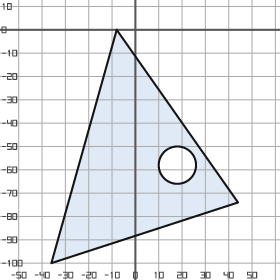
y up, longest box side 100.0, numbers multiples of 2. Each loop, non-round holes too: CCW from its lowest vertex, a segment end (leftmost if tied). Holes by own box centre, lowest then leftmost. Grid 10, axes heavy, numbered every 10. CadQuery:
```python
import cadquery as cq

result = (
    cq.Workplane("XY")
    .moveTo(-36.0, -100.0)
    .lineTo(44.0, -74.0)
    .lineTo(-8.0, 0.0)
    .close()
    .moveTo(18.0, -58.0)
    .circle(8.0)
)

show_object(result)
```